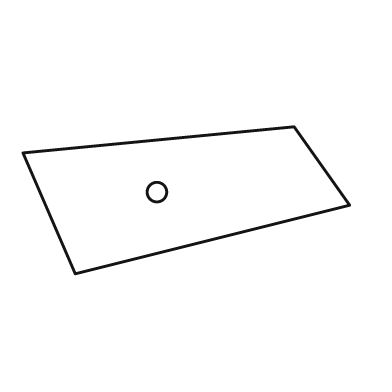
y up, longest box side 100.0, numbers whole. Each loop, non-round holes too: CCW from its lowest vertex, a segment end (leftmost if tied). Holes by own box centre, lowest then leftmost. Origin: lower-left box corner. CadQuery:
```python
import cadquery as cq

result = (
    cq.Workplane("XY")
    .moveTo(16.0, 0.0)
    .lineTo(100.0, 21.0)
    .lineTo(83.0, 45.0)
    .lineTo(0.0, 37.0)
    .close()
    .moveTo(41.0, 25.0)
    .circle(3.0)
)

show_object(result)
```